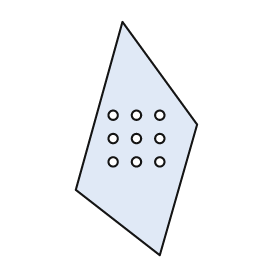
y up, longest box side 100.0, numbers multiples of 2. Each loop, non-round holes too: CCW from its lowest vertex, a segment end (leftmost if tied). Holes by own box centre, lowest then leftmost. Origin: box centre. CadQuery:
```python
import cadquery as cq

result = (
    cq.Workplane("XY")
    .moveTo(10.0, -50.0)
    .lineTo(26.0, 6.0)
    .lineTo(-6.0, 50.0)
    .lineTo(-26.0, -22.0)
    .close()
    .moveTo(-10.0, -10.0)
    .circle(2.0)
    .moveTo(0.0, -10.0)
    .circle(2.0)
    .moveTo(10.0, -10.0)
    .circle(2.0)
    .moveTo(-10.0, 0.0)
    .circle(2.0)
    .moveTo(0.0, 0.0)
    .circle(2.0)
    .moveTo(10.0, 0.0)
    .circle(2.0)
    .moveTo(-10.0, 10.0)
    .circle(2.0)
    .moveTo(0.0, 10.0)
    .circle(2.0)
    .moveTo(10.0, 10.0)
    .circle(2.0)
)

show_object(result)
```